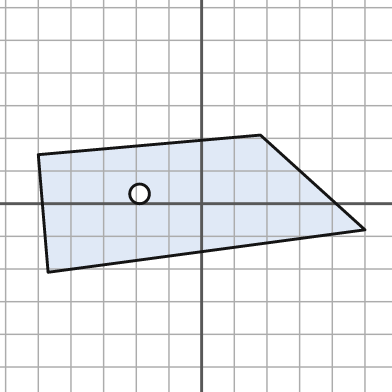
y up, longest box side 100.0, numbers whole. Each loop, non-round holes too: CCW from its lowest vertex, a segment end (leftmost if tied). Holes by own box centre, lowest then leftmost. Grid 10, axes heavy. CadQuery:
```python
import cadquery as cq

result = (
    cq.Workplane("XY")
    .moveTo(-47.0, -21.0)
    .lineTo(50.0, -8.0)
    .lineTo(18.0, 21.0)
    .lineTo(-50.0, 15.0)
    .close()
    .moveTo(-19.0, 3.0)
    .circle(3.0)
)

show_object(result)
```